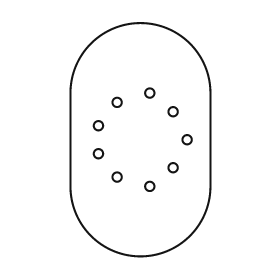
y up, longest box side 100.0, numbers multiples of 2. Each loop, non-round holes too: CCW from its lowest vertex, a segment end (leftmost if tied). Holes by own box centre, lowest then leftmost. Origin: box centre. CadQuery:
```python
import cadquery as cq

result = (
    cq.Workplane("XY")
    .moveTo(-30.0, -20.0)
    .threePointArc((0.0, -50.0), (30.0, -20.0))
    .lineTo(30.0, 20.0)
    .threePointArc((0.0, 50.0), (-30.0, 20.0))
    .close()
    .moveTo(4.0, -20.0)
    .circle(2.0)
    .moveTo(-10.0, -16.0)
    .circle(2.0)
    .moveTo(14.0, -12.0)
    .circle(2.0)
    .moveTo(-18.0, -6.0)
    .circle(2.0)
    .moveTo(20.0, 0.0)
    .circle(2.0)
    .moveTo(-18.0, 6.0)
    .circle(2.0)
    .moveTo(14.0, 12.0)
    .circle(2.0)
    .moveTo(-10.0, 16.0)
    .circle(2.0)
    .moveTo(4.0, 20.0)
    .circle(2.0)
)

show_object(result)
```